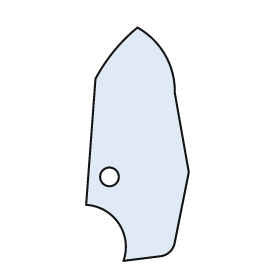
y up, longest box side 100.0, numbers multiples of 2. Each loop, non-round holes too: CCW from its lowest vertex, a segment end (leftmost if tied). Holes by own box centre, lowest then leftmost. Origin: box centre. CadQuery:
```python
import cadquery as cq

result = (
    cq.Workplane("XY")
    .moveTo(-6.0, -50.0)
    .lineTo(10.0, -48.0)
    .threePointArc((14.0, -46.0), (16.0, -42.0))
    .lineTo(22.0, -12.0)
    .lineTo(16.0, 22.0)
    .threePointArc((12.0, 38.0), (0.0, 50.0))
    .threePointArc((-10.0, 40.0), (-18.0, 28.0))
    .lineTo(-22.0, -26.0)
    .threePointArc((-8.0, -34.0), (-6.0, -50.0))
    .close()
    .moveTo(-12.0, -14.0)
    .circle(4.0)
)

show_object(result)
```